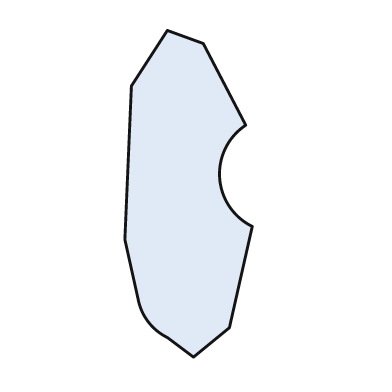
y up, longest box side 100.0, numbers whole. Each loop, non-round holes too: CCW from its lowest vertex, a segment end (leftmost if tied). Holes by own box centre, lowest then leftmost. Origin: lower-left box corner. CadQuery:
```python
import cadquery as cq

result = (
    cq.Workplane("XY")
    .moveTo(21.0, 0.0)
    .lineTo(32.0, 9.0)
    .lineTo(39.0, 40.0)
    .threePointArc((29.0, 55.0), (37.0, 71.0))
    .lineTo(24.0, 96.0)
    .lineTo(13.0, 100.0)
    .lineTo(2.0, 83.0)
    .lineTo(0.0, 36.0)
    .lineTo(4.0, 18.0)
    .threePointArc((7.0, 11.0), (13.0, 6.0))
    .close()
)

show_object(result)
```